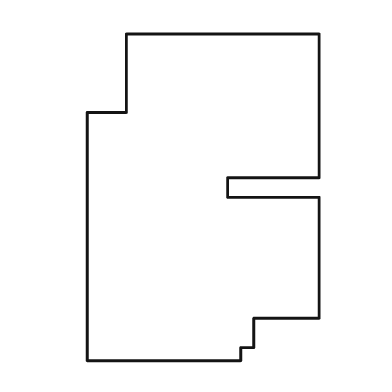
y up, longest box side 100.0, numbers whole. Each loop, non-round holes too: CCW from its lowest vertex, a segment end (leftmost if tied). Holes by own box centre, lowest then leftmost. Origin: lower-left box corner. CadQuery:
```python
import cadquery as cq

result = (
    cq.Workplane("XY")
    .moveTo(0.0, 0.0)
    .lineTo(47.0, 0.0)
    .lineTo(47.0, 4.0)
    .lineTo(51.0, 4.0)
    .lineTo(51.0, 13.0)
    .lineTo(71.0, 13.0)
    .lineTo(71.0, 50.0)
    .lineTo(43.0, 50.0)
    .lineTo(43.0, 56.0)
    .lineTo(71.0, 56.0)
    .lineTo(71.0, 100.0)
    .lineTo(12.0, 100.0)
    .lineTo(12.0, 76.0)
    .lineTo(0.0, 76.0)
    .close()
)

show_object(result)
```